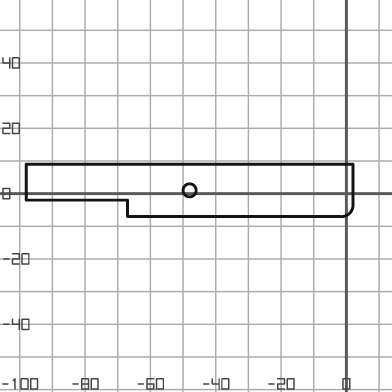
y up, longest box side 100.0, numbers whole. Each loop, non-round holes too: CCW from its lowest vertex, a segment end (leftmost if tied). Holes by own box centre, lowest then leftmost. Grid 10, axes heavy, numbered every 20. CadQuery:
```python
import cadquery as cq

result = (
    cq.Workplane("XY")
    .moveTo(-67.0, -7.0)
    .lineTo(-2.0, -7.0)
    .threePointArc((1.0, -6.0), (2.0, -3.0))
    .lineTo(2.0, 9.0)
    .lineTo(-98.0, 9.0)
    .lineTo(-98.0, -2.0)
    .lineTo(-67.0, -2.0)
    .close()
    .moveTo(-48.0, 1.0)
    .circle(2.0)
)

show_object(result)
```